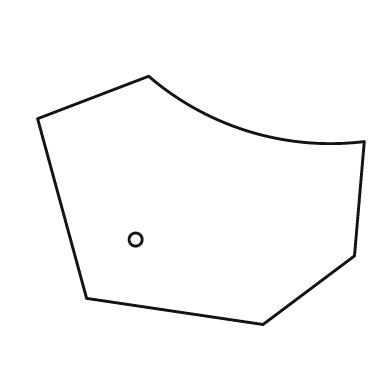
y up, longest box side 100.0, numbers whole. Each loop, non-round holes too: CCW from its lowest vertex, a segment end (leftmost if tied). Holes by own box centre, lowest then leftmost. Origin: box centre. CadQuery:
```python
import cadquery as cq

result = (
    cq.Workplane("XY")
    .moveTo(19.0, -38.0)
    .lineTo(47.0, -17.0)
    .lineTo(50.0, 18.0)
    .threePointArc((15.0, 21.0), (-16.0, 38.0))
    .lineTo(-50.0, 25.0)
    .lineTo(-35.0, -30.0)
    .close()
    .moveTo(-20.0, -12.0)
    .circle(2.0)
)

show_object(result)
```